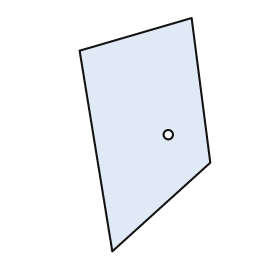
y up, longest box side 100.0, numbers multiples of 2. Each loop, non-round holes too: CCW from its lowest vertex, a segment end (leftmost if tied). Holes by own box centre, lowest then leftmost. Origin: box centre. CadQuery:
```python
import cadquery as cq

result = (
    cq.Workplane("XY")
    .moveTo(-14.0, -50.0)
    .lineTo(28.0, -12.0)
    .lineTo(20.0, 50.0)
    .lineTo(-28.0, 36.0)
    .close()
    .moveTo(10.0, 0.0)
    .circle(2.0)
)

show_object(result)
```